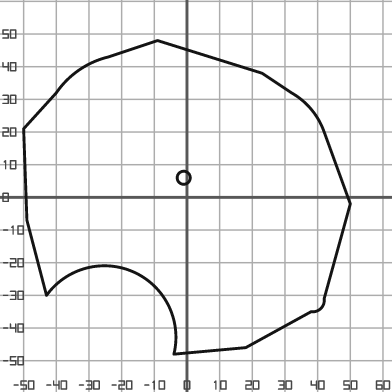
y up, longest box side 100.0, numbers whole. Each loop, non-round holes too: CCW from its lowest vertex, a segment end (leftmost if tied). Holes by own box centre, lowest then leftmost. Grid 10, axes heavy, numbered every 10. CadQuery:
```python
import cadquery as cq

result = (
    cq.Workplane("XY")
    .moveTo(-4.0, -48.0)
    .lineTo(18.0, -46.0)
    .lineTo(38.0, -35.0)
    .threePointArc((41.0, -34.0), (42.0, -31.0))
    .lineTo(50.0, -2.0)
    .lineTo(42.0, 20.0)
    .threePointArc((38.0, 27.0), (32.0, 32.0))
    .lineTo(23.0, 38.0)
    .lineTo(-9.0, 48.0)
    .lineTo(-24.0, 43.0)
    .threePointArc((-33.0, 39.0), (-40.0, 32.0))
    .lineTo(-50.0, 21.0)
    .lineTo(-49.0, -7.0)
    .lineTo(-43.0, -30.0)
    .threePointArc((-16.0, -23.0), (-4.0, -48.0))
    .close()
    .moveTo(-1.0, 6.0)
    .circle(2.0)
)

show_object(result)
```